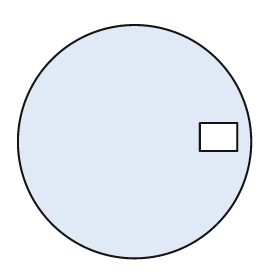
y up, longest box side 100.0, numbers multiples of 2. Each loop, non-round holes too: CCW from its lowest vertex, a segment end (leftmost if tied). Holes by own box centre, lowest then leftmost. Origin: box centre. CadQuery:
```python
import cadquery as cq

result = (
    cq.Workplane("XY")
    .moveTo(0.0, 0.0)
    .circle(50.0)
    .moveTo(28.0, -4.0)
    .lineTo(44.0, -4.0)
    .lineTo(44.0, 8.0)
    .lineTo(28.0, 8.0)
    .close()
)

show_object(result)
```